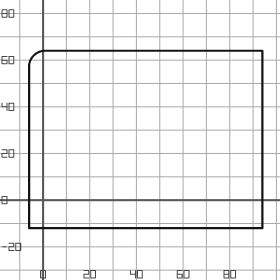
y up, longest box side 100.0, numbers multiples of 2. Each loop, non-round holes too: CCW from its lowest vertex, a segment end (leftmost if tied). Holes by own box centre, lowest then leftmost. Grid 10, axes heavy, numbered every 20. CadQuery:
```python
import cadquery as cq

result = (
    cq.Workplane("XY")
    .moveTo(-6.0, -12.0)
    .lineTo(94.0, -12.0)
    .lineTo(94.0, 64.0)
    .lineTo(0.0, 64.0)
    .threePointArc((-4.0, 62.0), (-6.0, 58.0))
    .close()
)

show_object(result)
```